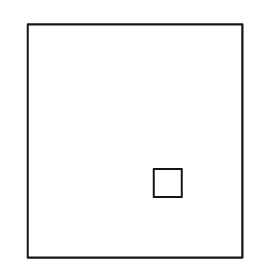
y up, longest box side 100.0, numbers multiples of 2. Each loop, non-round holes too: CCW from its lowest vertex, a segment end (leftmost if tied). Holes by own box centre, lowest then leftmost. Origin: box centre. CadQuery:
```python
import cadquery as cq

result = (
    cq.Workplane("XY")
    .moveTo(-46.0, -50.0)
    .lineTo(46.0, -50.0)
    .lineTo(46.0, 50.0)
    .lineTo(-46.0, 50.0)
    .close()
    .moveTo(8.0, -24.0)
    .lineTo(20.0, -24.0)
    .lineTo(20.0, -12.0)
    .lineTo(8.0, -12.0)
    .close()
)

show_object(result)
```